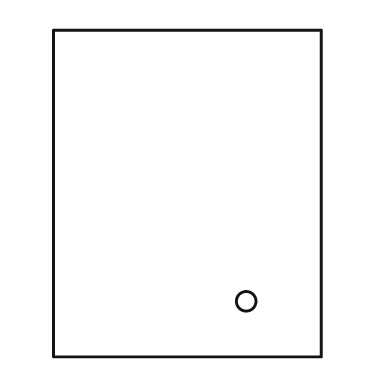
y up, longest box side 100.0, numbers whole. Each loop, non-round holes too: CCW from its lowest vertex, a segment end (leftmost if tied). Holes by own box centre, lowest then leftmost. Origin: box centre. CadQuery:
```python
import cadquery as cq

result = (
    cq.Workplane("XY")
    .moveTo(-41.0, -50.0)
    .lineTo(41.0, -50.0)
    .lineTo(41.0, 50.0)
    .lineTo(-41.0, 50.0)
    .close()
    .moveTo(18.0, -33.0)
    .circle(3.0)
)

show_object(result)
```